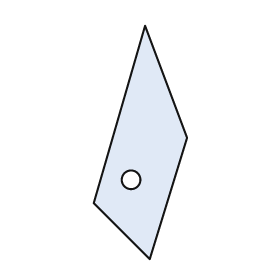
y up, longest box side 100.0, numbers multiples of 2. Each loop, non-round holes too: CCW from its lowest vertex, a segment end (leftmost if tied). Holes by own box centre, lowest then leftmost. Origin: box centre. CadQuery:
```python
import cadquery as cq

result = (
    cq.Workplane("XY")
    .moveTo(4.0, -50.0)
    .lineTo(20.0, 2.0)
    .lineTo(2.0, 50.0)
    .lineTo(-20.0, -26.0)
    .close()
    .moveTo(-4.0, -16.0)
    .circle(4.0)
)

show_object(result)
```